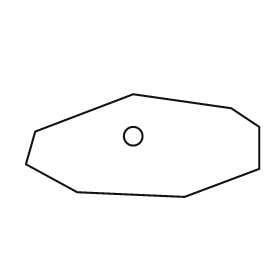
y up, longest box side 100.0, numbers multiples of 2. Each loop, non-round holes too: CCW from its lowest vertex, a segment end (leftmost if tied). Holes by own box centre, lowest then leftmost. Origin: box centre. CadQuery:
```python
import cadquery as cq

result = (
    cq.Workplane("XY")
    .moveTo(18.0, -22.0)
    .lineTo(50.0, -10.0)
    .lineTo(50.0, 8.0)
    .lineTo(38.0, 16.0)
    .lineTo(-4.0, 22.0)
    .lineTo(-46.0, 6.0)
    .lineTo(-50.0, -8.0)
    .lineTo(-28.0, -20.0)
    .close()
    .moveTo(-4.0, 4.0)
    .circle(4.0)
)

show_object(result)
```